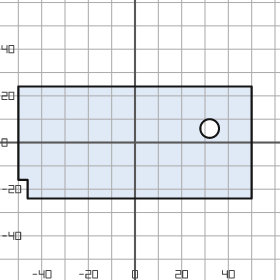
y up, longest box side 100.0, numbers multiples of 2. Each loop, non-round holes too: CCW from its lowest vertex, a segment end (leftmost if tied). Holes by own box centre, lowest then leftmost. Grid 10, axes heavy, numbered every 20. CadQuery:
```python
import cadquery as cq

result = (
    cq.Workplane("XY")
    .moveTo(-46.0, -24.0)
    .lineTo(50.0, -24.0)
    .lineTo(50.0, 24.0)
    .lineTo(-50.0, 24.0)
    .lineTo(-50.0, -16.0)
    .lineTo(-46.0, -16.0)
    .close()
    .moveTo(32.0, 6.0)
    .circle(4.0)
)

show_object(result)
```